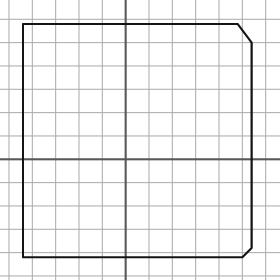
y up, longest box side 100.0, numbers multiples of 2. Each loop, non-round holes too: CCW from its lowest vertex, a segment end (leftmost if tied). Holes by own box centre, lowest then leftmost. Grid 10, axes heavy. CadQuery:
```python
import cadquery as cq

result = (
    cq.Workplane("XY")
    .moveTo(-44.0, -42.0)
    .lineTo(50.0, -42.0)
    .lineTo(54.0, -38.0)
    .lineTo(54.0, 50.0)
    .lineTo(48.0, 58.0)
    .lineTo(-44.0, 58.0)
    .close()
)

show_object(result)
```